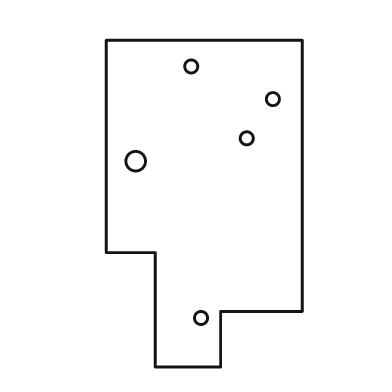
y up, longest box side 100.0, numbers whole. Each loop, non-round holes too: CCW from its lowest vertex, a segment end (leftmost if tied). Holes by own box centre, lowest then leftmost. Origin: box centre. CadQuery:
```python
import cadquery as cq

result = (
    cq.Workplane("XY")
    .moveTo(-15.0, -50.0)
    .lineTo(5.0, -50.0)
    .lineTo(5.0, -33.0)
    .lineTo(30.0, -33.0)
    .lineTo(30.0, 50.0)
    .lineTo(-30.0, 50.0)
    .lineTo(-30.0, -15.0)
    .lineTo(-15.0, -15.0)
    .close()
    .moveTo(-1.0, -35.0)
    .circle(2.0)
    .moveTo(-21.0, 13.0)
    .circle(3.0)
    .moveTo(13.0, 20.0)
    .circle(2.0)
    .moveTo(21.0, 32.0)
    .circle(2.0)
    .moveTo(-4.0, 42.0)
    .circle(2.0)
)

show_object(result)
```